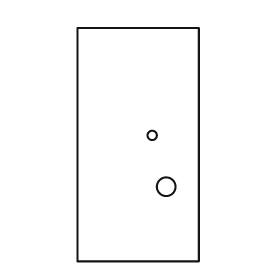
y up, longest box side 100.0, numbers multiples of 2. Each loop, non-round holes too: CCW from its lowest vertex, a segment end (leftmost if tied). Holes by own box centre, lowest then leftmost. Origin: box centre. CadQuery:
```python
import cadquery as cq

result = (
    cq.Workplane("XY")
    .moveTo(-26.0, -50.0)
    .lineTo(26.0, -50.0)
    .lineTo(26.0, 50.0)
    .lineTo(-26.0, 50.0)
    .close()
    .moveTo(12.0, -18.0)
    .circle(4.0)
    .moveTo(6.0, 4.0)
    .circle(2.0)
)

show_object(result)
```